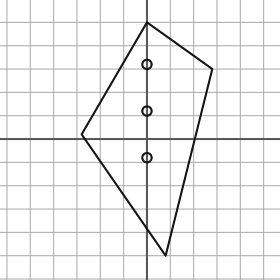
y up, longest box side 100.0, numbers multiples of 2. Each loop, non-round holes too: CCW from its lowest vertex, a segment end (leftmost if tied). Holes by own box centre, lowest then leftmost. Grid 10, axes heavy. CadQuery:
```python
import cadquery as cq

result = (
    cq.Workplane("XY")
    .moveTo(8.0, -50.0)
    .lineTo(28.0, 30.0)
    .lineTo(0.0, 50.0)
    .lineTo(-28.0, 2.0)
    .close()
    .moveTo(0.0, -8.0)
    .circle(2.0)
    .moveTo(0.0, 12.0)
    .circle(2.0)
    .moveTo(0.0, 32.0)
    .circle(2.0)
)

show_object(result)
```